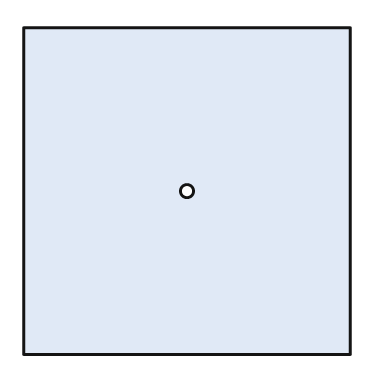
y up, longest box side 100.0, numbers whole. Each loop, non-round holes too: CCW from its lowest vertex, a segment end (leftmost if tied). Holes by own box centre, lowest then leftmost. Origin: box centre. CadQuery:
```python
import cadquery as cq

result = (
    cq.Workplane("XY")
    .moveTo(-50.0, -50.0)
    .lineTo(50.0, -50.0)
    .lineTo(50.0, 50.0)
    .lineTo(-50.0, 50.0)
    .close()
    .moveTo(0.0, 0.0)
    .circle(2.0)
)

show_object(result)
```